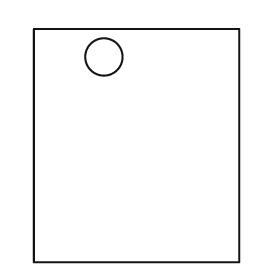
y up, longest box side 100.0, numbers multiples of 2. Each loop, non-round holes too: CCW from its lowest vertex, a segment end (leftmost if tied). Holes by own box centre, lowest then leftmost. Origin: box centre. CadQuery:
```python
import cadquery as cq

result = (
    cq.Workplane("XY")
    .moveTo(-44.0, -50.0)
    .lineTo(44.0, -50.0)
    .lineTo(44.0, 50.0)
    .lineTo(-44.0, 50.0)
    .close()
    .moveTo(-14.0, 38.0)
    .circle(8.0)
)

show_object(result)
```